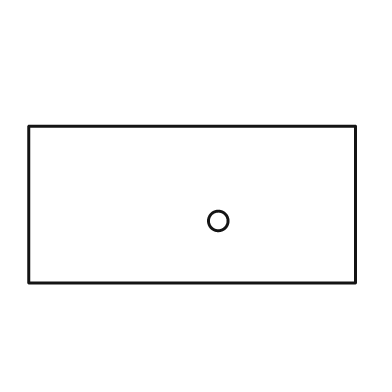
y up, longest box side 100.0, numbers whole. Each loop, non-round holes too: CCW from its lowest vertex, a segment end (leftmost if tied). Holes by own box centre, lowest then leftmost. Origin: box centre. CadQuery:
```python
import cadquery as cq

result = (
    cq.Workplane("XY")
    .moveTo(-50.0, -24.0)
    .lineTo(50.0, -24.0)
    .lineTo(50.0, 24.0)
    .lineTo(-50.0, 24.0)
    .close()
    .moveTo(8.0, -5.0)
    .circle(3.0)
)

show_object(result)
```